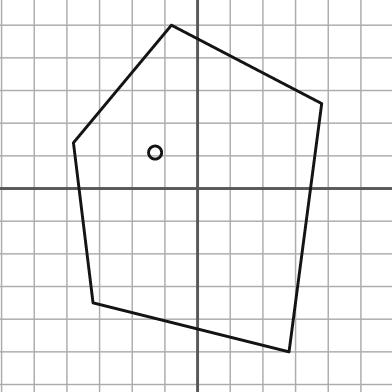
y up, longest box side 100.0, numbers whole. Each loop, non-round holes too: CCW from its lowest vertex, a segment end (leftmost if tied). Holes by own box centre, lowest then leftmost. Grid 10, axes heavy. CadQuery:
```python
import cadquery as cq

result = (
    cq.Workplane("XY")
    .moveTo(28.0, -50.0)
    .lineTo(38.0, 26.0)
    .lineTo(-8.0, 50.0)
    .lineTo(-38.0, 14.0)
    .lineTo(-32.0, -35.0)
    .close()
    .moveTo(-13.0, 11.0)
    .circle(2.0)
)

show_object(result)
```